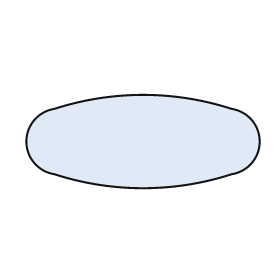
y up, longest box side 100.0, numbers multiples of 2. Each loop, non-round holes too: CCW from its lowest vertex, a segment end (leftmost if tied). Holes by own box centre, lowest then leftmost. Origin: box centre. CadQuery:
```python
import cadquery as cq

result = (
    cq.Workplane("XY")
    .moveTo(-38.0, -14.0)
    .threePointArc((0.0, -20.0), (38.0, -14.0))
    .threePointArc((50.0, 0.0), (38.0, 14.0))
    .threePointArc((0.0, 20.0), (-38.0, 14.0))
    .threePointArc((-50.0, 0.0), (-38.0, -14.0))
    .close()
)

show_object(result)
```